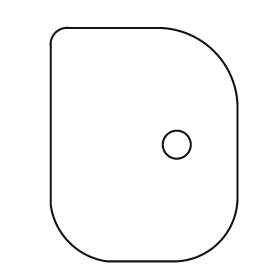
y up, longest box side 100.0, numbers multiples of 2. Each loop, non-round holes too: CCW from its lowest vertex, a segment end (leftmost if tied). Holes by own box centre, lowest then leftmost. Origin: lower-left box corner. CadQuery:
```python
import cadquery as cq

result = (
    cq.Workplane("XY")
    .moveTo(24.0, 0.0)
    .lineTo(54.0, 0.0)
    .threePointArc((72.0, 8.0), (80.0, 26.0))
    .lineTo(80.0, 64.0)
    .threePointArc((70.0, 90.0), (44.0, 100.0))
    .lineTo(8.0, 100.0)
    .threePointArc((2.0, 98.0), (0.0, 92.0))
    .lineTo(0.0, 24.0)
    .threePointArc((8.0, 8.0), (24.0, 0.0))
    .close()
    .moveTo(54.0, 50.0)
    .circle(6.0)
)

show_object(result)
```